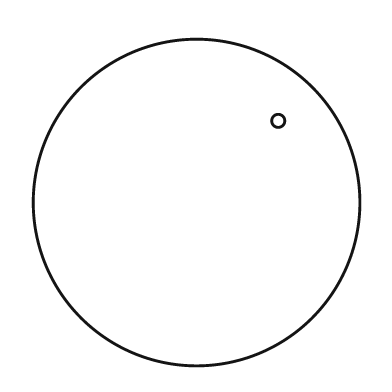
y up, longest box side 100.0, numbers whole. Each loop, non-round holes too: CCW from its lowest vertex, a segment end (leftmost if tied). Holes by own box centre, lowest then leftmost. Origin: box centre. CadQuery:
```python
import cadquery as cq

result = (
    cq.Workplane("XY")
    .moveTo(0.0, 0.0)
    .circle(50.0)
    .moveTo(25.0, 25.0)
    .circle(2.0)
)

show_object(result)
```